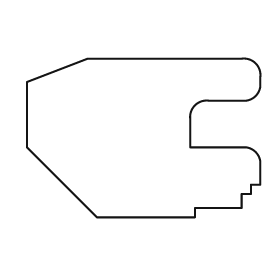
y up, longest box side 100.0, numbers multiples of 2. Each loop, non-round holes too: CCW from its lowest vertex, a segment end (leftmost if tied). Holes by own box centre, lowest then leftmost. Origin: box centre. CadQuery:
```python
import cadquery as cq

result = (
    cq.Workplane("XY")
    .moveTo(-20.0, -34.0)
    .lineTo(22.0, -34.0)
    .lineTo(22.0, -30.0)
    .lineTo(42.0, -30.0)
    .lineTo(42.0, -24.0)
    .lineTo(46.0, -24.0)
    .lineTo(46.0, -20.0)
    .lineTo(50.0, -20.0)
    .lineTo(50.0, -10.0)
    .threePointArc((48.0, -6.0), (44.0, -4.0))
    .lineTo(20.0, -4.0)
    .lineTo(20.0, 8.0)
    .threePointArc((22.0, 14.0), (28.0, 16.0))
    .lineTo(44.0, 16.0)
    .threePointArc((48.0, 18.0), (50.0, 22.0))
    .lineTo(50.0, 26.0)
    .threePointArc((48.0, 32.0), (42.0, 34.0))
    .lineTo(-24.0, 34.0)
    .lineTo(-50.0, 24.0)
    .lineTo(-50.0, -4.0)
    .close()
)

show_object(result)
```